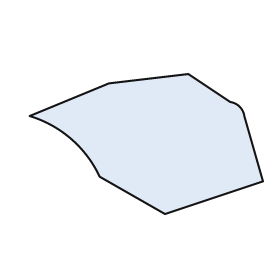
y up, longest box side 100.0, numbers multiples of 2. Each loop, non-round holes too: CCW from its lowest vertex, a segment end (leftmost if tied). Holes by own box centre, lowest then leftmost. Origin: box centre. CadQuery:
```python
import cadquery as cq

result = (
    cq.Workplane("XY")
    .moveTo(8.0, -30.0)
    .lineTo(50.0, -16.0)
    .lineTo(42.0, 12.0)
    .threePointArc((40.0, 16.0), (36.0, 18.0))
    .lineTo(18.0, 30.0)
    .lineTo(-16.0, 26.0)
    .lineTo(-50.0, 12.0)
    .threePointArc((-32.0, 2.0), (-20.0, -14.0))
    .close()
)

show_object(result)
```